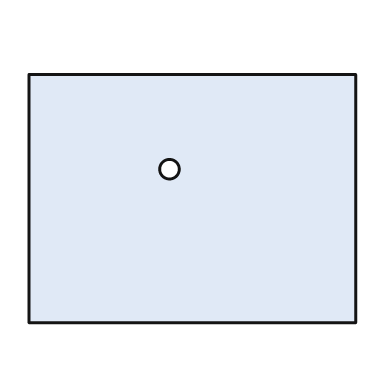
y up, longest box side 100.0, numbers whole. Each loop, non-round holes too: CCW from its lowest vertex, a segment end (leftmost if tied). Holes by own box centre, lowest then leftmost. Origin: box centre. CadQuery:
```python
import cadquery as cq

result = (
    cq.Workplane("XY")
    .moveTo(-50.0, -38.0)
    .lineTo(50.0, -38.0)
    .lineTo(50.0, 38.0)
    .lineTo(-50.0, 38.0)
    .close()
    .moveTo(-7.0, 9.0)
    .circle(3.0)
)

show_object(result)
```